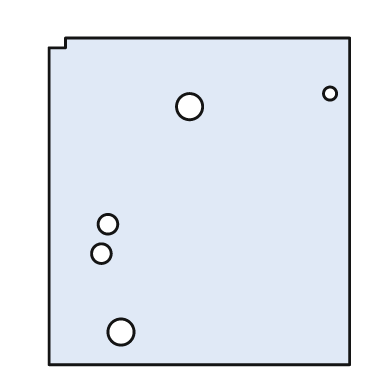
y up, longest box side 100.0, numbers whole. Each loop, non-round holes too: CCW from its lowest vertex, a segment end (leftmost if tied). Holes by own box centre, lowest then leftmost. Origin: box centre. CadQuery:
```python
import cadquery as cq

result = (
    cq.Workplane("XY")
    .moveTo(-46.0, -50.0)
    .lineTo(46.0, -50.0)
    .lineTo(46.0, 50.0)
    .lineTo(-41.0, 50.0)
    .lineTo(-41.0, 47.0)
    .lineTo(-46.0, 47.0)
    .close()
    .moveTo(-24.0, -40.0)
    .circle(4.0)
    .moveTo(-30.0, -16.0)
    .circle(3.0)
    .moveTo(-28.0, -7.0)
    .circle(3.0)
    .moveTo(-3.0, 29.0)
    .circle(4.0)
    .moveTo(40.0, 33.0)
    .circle(2.0)
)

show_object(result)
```